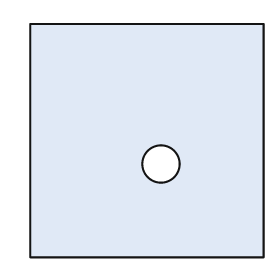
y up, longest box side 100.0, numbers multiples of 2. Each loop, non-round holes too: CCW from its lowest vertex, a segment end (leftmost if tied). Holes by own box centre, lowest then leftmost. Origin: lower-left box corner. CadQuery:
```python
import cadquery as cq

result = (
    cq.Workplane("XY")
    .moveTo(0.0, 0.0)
    .lineTo(100.0, 0.0)
    .lineTo(100.0, 100.0)
    .lineTo(0.0, 100.0)
    .close()
    .moveTo(56.0, 40.0)
    .circle(8.0)
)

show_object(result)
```